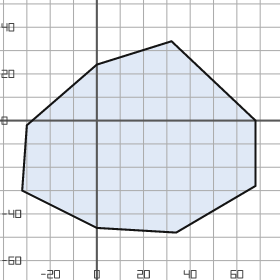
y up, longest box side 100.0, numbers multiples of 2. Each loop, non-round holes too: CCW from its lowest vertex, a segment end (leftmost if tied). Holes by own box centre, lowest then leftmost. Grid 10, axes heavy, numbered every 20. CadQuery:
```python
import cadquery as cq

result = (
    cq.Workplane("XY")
    .moveTo(34.0, -48.0)
    .lineTo(68.0, -28.0)
    .lineTo(68.0, 0.0)
    .lineTo(32.0, 34.0)
    .lineTo(0.0, 24.0)
    .lineTo(-30.0, -2.0)
    .lineTo(-32.0, -30.0)
    .lineTo(0.0, -46.0)
    .close()
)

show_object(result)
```